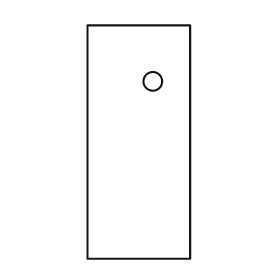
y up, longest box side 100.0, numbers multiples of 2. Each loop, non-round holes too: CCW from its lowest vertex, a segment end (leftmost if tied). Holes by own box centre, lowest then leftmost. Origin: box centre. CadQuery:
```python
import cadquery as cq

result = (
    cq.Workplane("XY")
    .moveTo(-22.0, -50.0)
    .lineTo(22.0, -50.0)
    .lineTo(22.0, 50.0)
    .lineTo(-22.0, 50.0)
    .close()
    .moveTo(6.0, 26.0)
    .circle(4.0)
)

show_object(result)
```